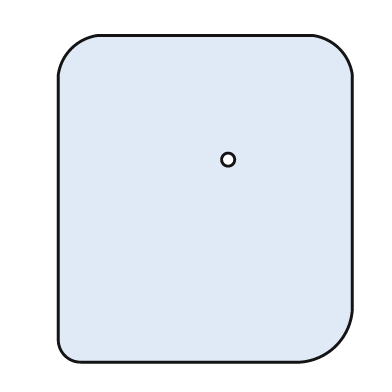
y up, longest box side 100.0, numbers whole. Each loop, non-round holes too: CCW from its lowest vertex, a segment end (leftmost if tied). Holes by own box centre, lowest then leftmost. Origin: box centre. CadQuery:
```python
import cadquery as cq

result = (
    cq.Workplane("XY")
    .moveTo(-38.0, -50.0)
    .lineTo(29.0, -50.0)
    .threePointArc((40.0, -45.0), (45.0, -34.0))
    .lineTo(45.0, 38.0)
    .threePointArc((41.0, 46.0), (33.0, 50.0))
    .lineTo(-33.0, 50.0)
    .threePointArc((-41.0, 46.0), (-45.0, 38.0))
    .lineTo(-45.0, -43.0)
    .threePointArc((-43.0, -48.0), (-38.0, -50.0))
    .close()
    .moveTo(7.0, 12.0)
    .circle(2.0)
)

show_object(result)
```